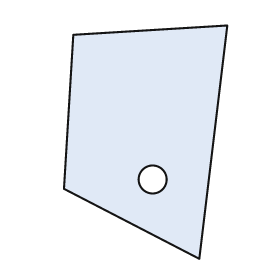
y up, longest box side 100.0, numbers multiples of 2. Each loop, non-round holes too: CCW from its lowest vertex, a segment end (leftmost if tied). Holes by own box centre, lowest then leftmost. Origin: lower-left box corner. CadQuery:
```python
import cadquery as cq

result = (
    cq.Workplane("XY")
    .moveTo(58.0, 0.0)
    .lineTo(70.0, 100.0)
    .lineTo(4.0, 96.0)
    .lineTo(0.0, 30.0)
    .close()
    .moveTo(38.0, 34.0)
    .circle(6.0)
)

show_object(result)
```